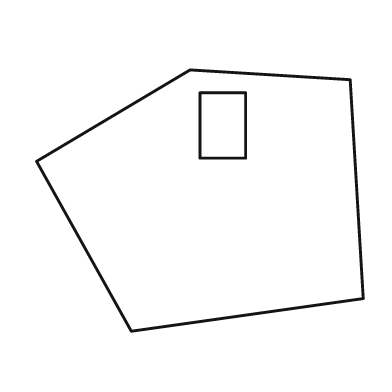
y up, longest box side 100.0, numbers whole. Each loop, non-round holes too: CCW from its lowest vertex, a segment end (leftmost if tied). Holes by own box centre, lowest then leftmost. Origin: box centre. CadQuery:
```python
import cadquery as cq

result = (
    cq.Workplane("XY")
    .moveTo(-21.0, -40.0)
    .lineTo(50.0, -30.0)
    .lineTo(46.0, 37.0)
    .lineTo(-3.0, 40.0)
    .lineTo(-50.0, 12.0)
    .close()
    .moveTo(0.0, 13.0)
    .lineTo(14.0, 13.0)
    .lineTo(14.0, 33.0)
    .lineTo(0.0, 33.0)
    .close()
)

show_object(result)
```